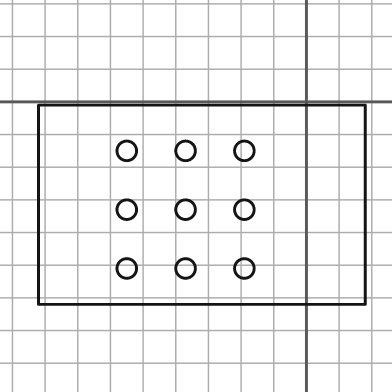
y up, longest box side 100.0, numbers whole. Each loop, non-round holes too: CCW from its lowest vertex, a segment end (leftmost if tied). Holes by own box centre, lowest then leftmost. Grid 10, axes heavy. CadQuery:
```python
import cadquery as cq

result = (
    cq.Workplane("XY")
    .moveTo(-82.0, -62.0)
    .lineTo(18.0, -62.0)
    .lineTo(18.0, -1.0)
    .lineTo(-82.0, -1.0)
    .close()
    .moveTo(-55.0, -51.0)
    .circle(3.0)
    .moveTo(-37.0, -51.0)
    .circle(3.0)
    .moveTo(-19.0, -51.0)
    .circle(3.0)
    .moveTo(-55.0, -33.0)
    .circle(3.0)
    .moveTo(-37.0, -33.0)
    .circle(3.0)
    .moveTo(-19.0, -33.0)
    .circle(3.0)
    .moveTo(-55.0, -15.0)
    .circle(3.0)
    .moveTo(-37.0, -15.0)
    .circle(3.0)
    .moveTo(-19.0, -15.0)
    .circle(3.0)
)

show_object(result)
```